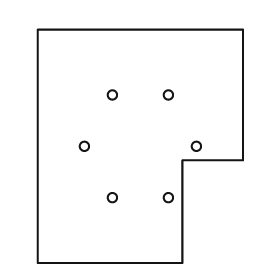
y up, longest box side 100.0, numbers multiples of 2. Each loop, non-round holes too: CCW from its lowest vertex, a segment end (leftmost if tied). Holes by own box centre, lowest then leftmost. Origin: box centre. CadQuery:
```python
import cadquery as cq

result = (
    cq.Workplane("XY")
    .moveTo(-44.0, -50.0)
    .lineTo(18.0, -50.0)
    .lineTo(18.0, -6.0)
    .lineTo(44.0, -6.0)
    .lineTo(44.0, 50.0)
    .lineTo(-44.0, 50.0)
    .close()
    .moveTo(-12.0, -22.0)
    .circle(2.0)
    .moveTo(12.0, -22.0)
    .circle(2.0)
    .moveTo(-24.0, 0.0)
    .circle(2.0)
    .moveTo(24.0, 0.0)
    .circle(2.0)
    .moveTo(-12.0, 22.0)
    .circle(2.0)
    .moveTo(12.0, 22.0)
    .circle(2.0)
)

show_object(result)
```